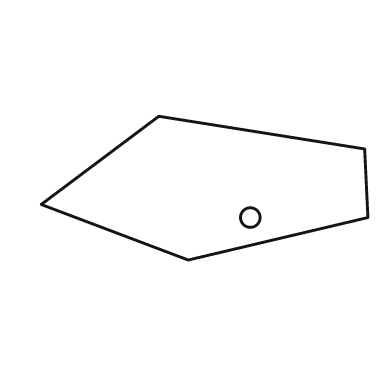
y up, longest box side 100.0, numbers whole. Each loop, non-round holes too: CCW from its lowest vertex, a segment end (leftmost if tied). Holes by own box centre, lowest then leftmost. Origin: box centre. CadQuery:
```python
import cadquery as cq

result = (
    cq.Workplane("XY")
    .moveTo(-5.0, -22.0)
    .lineTo(50.0, -9.0)
    .lineTo(49.0, 12.0)
    .lineTo(-14.0, 22.0)
    .lineTo(-50.0, -5.0)
    .close()
    .moveTo(14.0, -9.0)
    .circle(3.0)
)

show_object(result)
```